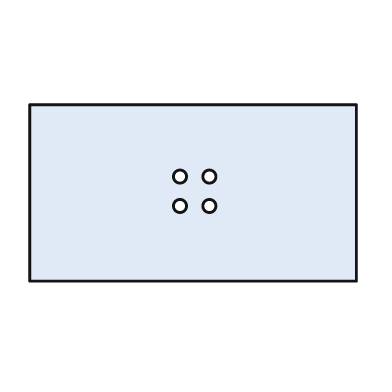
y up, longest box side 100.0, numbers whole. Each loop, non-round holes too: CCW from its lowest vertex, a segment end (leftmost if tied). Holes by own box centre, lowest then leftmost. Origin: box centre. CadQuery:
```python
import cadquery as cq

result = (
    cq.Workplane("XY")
    .moveTo(-50.0, -27.0)
    .lineTo(50.0, -27.0)
    .lineTo(50.0, 27.0)
    .lineTo(-50.0, 27.0)
    .close()
    .moveTo(-4.0, -4.0)
    .circle(2.0)
    .moveTo(5.0, -4.0)
    .circle(2.0)
    .moveTo(-4.0, 5.0)
    .circle(2.0)
    .moveTo(5.0, 5.0)
    .circle(2.0)
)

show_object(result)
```